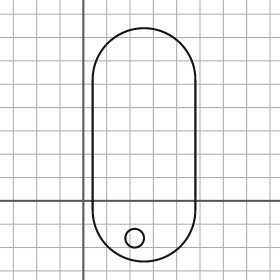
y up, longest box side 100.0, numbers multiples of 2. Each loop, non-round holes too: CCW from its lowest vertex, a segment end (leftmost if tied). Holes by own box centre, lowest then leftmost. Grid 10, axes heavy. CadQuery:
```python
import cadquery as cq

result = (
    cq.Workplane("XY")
    .moveTo(4.0, -4.0)
    .threePointArc((26.0, -26.0), (48.0, -4.0))
    .lineTo(48.0, 52.0)
    .threePointArc((26.0, 74.0), (4.0, 52.0))
    .close()
    .moveTo(22.0, -16.0)
    .circle(4.0)
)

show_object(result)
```